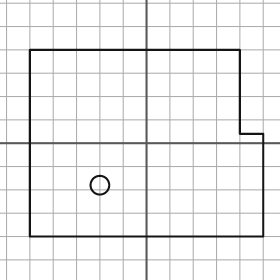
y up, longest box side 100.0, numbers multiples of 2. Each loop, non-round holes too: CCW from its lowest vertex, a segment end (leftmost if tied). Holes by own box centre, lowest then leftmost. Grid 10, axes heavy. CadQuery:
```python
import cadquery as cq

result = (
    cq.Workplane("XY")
    .moveTo(-50.0, -40.0)
    .lineTo(50.0, -40.0)
    .lineTo(50.0, 4.0)
    .lineTo(40.0, 4.0)
    .lineTo(40.0, 40.0)
    .lineTo(-50.0, 40.0)
    .close()
    .moveTo(-20.0, -18.0)
    .circle(4.0)
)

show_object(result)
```